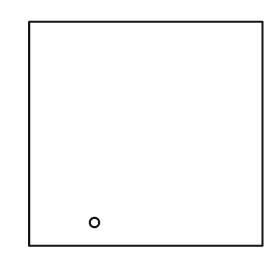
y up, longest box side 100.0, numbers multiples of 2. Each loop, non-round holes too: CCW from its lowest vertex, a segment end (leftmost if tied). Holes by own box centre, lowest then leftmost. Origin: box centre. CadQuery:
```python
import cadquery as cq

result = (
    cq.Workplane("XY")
    .moveTo(-50.0, -48.0)
    .lineTo(50.0, -48.0)
    .lineTo(50.0, 48.0)
    .lineTo(-50.0, 48.0)
    .close()
    .moveTo(-22.0, -38.0)
    .circle(2.0)
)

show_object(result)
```